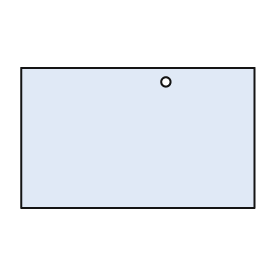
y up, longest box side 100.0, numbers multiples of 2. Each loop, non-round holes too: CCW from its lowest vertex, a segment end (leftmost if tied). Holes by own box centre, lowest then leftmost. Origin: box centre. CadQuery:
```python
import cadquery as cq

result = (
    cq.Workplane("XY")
    .moveTo(-50.0, -30.0)
    .lineTo(50.0, -30.0)
    .lineTo(50.0, 30.0)
    .lineTo(-50.0, 30.0)
    .close()
    .moveTo(12.0, 24.0)
    .circle(2.0)
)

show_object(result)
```